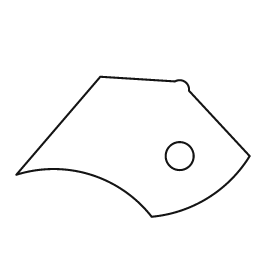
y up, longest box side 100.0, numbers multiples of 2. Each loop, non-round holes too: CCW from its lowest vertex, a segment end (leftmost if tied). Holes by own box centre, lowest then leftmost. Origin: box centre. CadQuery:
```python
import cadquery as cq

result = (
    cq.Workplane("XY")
    .moveTo(8.0, -30.0)
    .threePointArc((32.0, -22.0), (50.0, -4.0))
    .lineTo(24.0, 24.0)
    .threePointArc((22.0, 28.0), (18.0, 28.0))
    .lineTo(-14.0, 30.0)
    .lineTo(-50.0, -12.0)
    .threePointArc((-18.0, -12.0), (8.0, -30.0))
    .close()
    .moveTo(20.0, -4.0)
    .circle(6.0)
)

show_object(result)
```